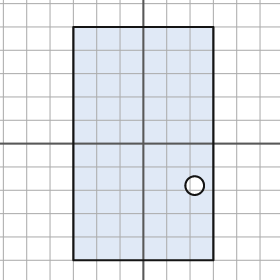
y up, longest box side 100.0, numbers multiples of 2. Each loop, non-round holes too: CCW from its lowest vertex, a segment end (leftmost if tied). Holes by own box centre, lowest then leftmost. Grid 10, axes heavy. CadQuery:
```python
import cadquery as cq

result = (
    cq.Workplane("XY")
    .moveTo(-30.0, -50.0)
    .lineTo(30.0, -50.0)
    .lineTo(30.0, 50.0)
    .lineTo(-30.0, 50.0)
    .close()
    .moveTo(22.0, -18.0)
    .circle(4.0)
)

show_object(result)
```